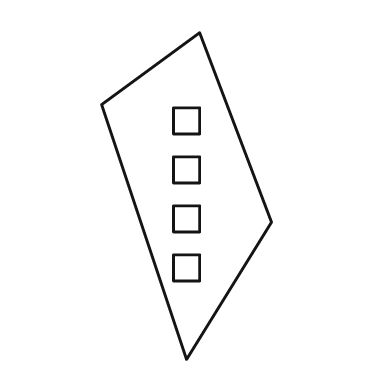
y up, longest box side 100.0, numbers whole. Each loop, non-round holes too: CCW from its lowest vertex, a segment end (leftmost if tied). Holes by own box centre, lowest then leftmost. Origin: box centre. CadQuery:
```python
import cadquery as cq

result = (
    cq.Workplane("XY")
    .moveTo(0.0, -50.0)
    .lineTo(26.0, -8.0)
    .lineTo(4.0, 50.0)
    .lineTo(-26.0, 28.0)
    .close()
    .moveTo(-4.0, -26.0)
    .lineTo(4.0, -26.0)
    .lineTo(4.0, -18.0)
    .lineTo(-4.0, -18.0)
    .close()
    .moveTo(-4.0, -11.0)
    .lineTo(4.0, -11.0)
    .lineTo(4.0, -3.0)
    .lineTo(-4.0, -3.0)
    .close()
    .moveTo(-4.0, 4.0)
    .lineTo(4.0, 4.0)
    .lineTo(4.0, 12.0)
    .lineTo(-4.0, 12.0)
    .close()
    .moveTo(-4.0, 19.0)
    .lineTo(4.0, 19.0)
    .lineTo(4.0, 27.0)
    .lineTo(-4.0, 27.0)
    .close()
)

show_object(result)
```